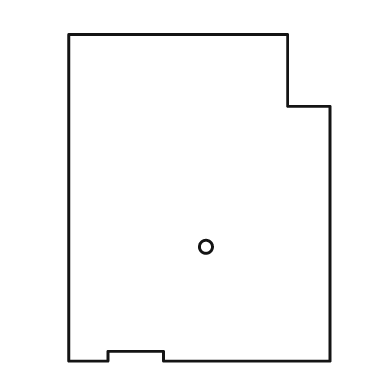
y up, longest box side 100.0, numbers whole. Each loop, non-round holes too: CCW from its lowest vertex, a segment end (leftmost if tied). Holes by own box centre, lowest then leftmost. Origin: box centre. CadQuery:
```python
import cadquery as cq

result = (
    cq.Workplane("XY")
    .moveTo(-40.0, -50.0)
    .lineTo(-28.0, -50.0)
    .lineTo(-28.0, -47.0)
    .lineTo(-11.0, -47.0)
    .lineTo(-11.0, -50.0)
    .lineTo(40.0, -50.0)
    .lineTo(40.0, 28.0)
    .lineTo(27.0, 28.0)
    .lineTo(27.0, 50.0)
    .lineTo(-40.0, 50.0)
    .close()
    .moveTo(2.0, -15.0)
    .circle(2.0)
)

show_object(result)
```